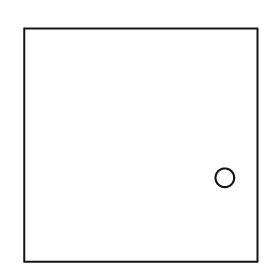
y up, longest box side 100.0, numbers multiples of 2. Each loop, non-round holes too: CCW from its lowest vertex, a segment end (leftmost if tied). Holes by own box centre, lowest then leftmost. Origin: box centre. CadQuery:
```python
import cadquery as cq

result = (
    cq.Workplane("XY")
    .moveTo(-50.0, -50.0)
    .lineTo(50.0, -50.0)
    .lineTo(50.0, 50.0)
    .lineTo(-50.0, 50.0)
    .close()
    .moveTo(36.0, -14.0)
    .circle(4.0)
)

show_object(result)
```